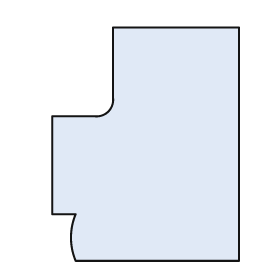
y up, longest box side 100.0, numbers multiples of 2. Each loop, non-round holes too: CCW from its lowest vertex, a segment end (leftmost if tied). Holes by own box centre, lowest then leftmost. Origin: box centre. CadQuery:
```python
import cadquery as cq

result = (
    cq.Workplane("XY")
    .moveTo(-30.0, -50.0)
    .lineTo(40.0, -50.0)
    .lineTo(40.0, 50.0)
    .lineTo(-14.0, 50.0)
    .lineTo(-14.0, 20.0)
    .threePointArc((-16.0, 14.0), (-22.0, 12.0))
    .lineTo(-40.0, 12.0)
    .lineTo(-40.0, -30.0)
    .lineTo(-30.0, -30.0)
    .threePointArc((-32.0, -40.0), (-30.0, -50.0))
    .close()
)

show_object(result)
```